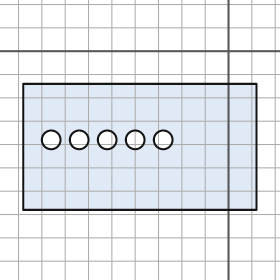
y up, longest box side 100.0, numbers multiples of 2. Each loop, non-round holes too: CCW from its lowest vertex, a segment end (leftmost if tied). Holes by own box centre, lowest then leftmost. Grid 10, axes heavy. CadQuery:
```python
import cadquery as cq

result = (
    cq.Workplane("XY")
    .moveTo(-88.0, -68.0)
    .lineTo(12.0, -68.0)
    .lineTo(12.0, -14.0)
    .lineTo(-88.0, -14.0)
    .close()
    .moveTo(-76.0, -38.0)
    .circle(4.0)
    .moveTo(-64.0, -38.0)
    .circle(4.0)
    .moveTo(-52.0, -38.0)
    .circle(4.0)
    .moveTo(-40.0, -38.0)
    .circle(4.0)
    .moveTo(-28.0, -38.0)
    .circle(4.0)
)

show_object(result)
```